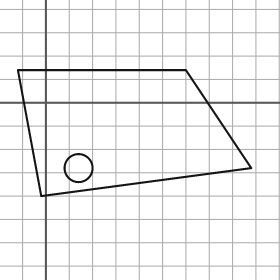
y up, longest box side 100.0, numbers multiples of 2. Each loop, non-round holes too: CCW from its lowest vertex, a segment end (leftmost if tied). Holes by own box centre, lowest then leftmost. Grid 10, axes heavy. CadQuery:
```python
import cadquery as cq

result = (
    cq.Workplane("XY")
    .moveTo(-2.0, -40.0)
    .lineTo(88.0, -28.0)
    .lineTo(60.0, 14.0)
    .lineTo(-12.0, 14.0)
    .close()
    .moveTo(14.0, -28.0)
    .circle(6.0)
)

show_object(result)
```